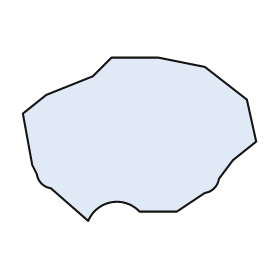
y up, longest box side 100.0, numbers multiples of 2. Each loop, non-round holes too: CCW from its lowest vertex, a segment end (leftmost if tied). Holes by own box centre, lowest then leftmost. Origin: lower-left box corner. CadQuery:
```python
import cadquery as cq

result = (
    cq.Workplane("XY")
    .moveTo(28.0, 0.0)
    .threePointArc((38.0, 8.0), (50.0, 4.0))
    .lineTo(66.0, 4.0)
    .lineTo(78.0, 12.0)
    .threePointArc((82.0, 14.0), (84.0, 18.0))
    .lineTo(90.0, 26.0)
    .lineTo(100.0, 34.0)
    .lineTo(96.0, 52.0)
    .lineTo(78.0, 66.0)
    .lineTo(58.0, 70.0)
    .lineTo(38.0, 70.0)
    .lineTo(30.0, 62.0)
    .lineTo(10.0, 54.0)
    .lineTo(0.0, 46.0)
    .lineTo(4.0, 24.0)
    .lineTo(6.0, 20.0)
    .threePointArc((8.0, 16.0), (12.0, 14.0))
    .close()
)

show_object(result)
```